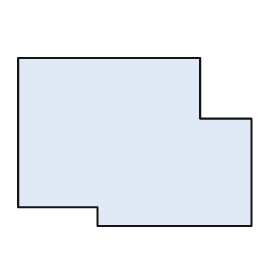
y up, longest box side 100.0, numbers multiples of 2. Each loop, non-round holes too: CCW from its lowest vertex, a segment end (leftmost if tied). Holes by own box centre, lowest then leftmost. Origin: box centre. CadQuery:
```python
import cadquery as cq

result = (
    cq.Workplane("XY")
    .moveTo(-16.0, -36.0)
    .lineTo(50.0, -36.0)
    .lineTo(50.0, 10.0)
    .lineTo(28.0, 10.0)
    .lineTo(28.0, 36.0)
    .lineTo(-50.0, 36.0)
    .lineTo(-50.0, -28.0)
    .lineTo(-16.0, -28.0)
    .close()
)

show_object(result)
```